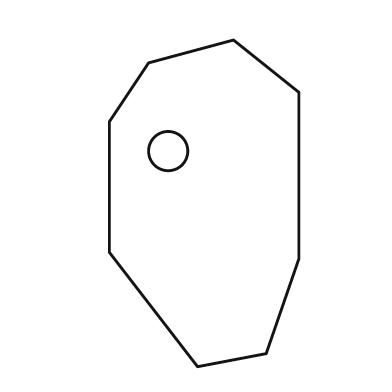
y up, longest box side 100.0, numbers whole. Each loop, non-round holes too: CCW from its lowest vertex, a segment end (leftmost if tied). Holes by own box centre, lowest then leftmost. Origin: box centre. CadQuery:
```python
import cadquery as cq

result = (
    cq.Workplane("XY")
    .moveTo(-2.0, -50.0)
    .lineTo(19.0, -46.0)
    .lineTo(29.0, -17.0)
    .lineTo(29.0, 34.0)
    .lineTo(9.0, 50.0)
    .lineTo(-17.0, 43.0)
    .lineTo(-29.0, 25.0)
    .lineTo(-29.0, -15.0)
    .close()
    .moveTo(-11.0, 16.0)
    .circle(6.0)
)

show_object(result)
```